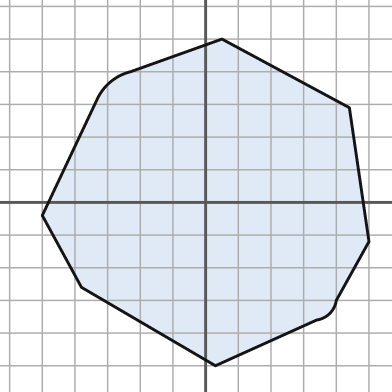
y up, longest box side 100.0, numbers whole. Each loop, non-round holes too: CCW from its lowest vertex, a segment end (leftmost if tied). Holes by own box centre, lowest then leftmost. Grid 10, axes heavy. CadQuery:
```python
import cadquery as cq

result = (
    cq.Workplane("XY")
    .moveTo(3.0, -50.0)
    .lineTo(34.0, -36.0)
    .threePointArc((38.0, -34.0), (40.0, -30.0))
    .lineTo(50.0, -12.0)
    .lineTo(44.0, 29.0)
    .lineTo(5.0, 50.0)
    .lineTo(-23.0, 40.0)
    .threePointArc((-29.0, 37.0), (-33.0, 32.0))
    .lineTo(-50.0, -4.0)
    .lineTo(-38.0, -26.0)
    .close()
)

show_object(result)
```